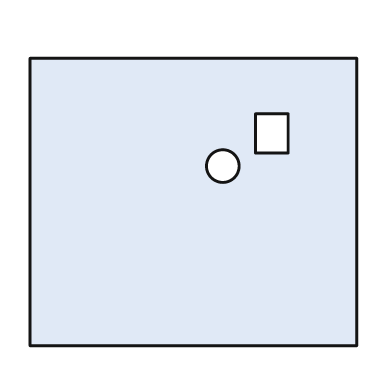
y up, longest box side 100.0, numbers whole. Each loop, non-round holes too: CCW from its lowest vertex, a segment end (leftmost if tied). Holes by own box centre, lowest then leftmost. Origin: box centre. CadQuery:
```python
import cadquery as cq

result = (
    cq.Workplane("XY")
    .moveTo(-50.0, -44.0)
    .lineTo(50.0, -44.0)
    .lineTo(50.0, 44.0)
    .lineTo(-50.0, 44.0)
    .close()
    .moveTo(9.0, 11.0)
    .circle(5.0)
    .moveTo(19.0, 15.0)
    .lineTo(29.0, 15.0)
    .lineTo(29.0, 27.0)
    .lineTo(19.0, 27.0)
    .close()
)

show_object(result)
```